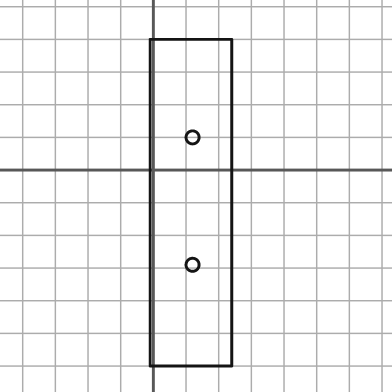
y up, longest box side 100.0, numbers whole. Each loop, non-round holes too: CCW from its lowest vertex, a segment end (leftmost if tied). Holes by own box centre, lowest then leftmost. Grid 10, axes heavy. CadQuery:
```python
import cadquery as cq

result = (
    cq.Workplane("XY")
    .moveTo(-1.0, -60.0)
    .lineTo(24.0, -60.0)
    .lineTo(24.0, 40.0)
    .lineTo(-1.0, 40.0)
    .close()
    .moveTo(12.0, -29.0)
    .circle(2.0)
    .moveTo(12.0, 10.0)
    .circle(2.0)
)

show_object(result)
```